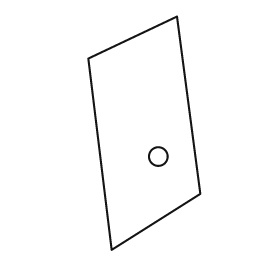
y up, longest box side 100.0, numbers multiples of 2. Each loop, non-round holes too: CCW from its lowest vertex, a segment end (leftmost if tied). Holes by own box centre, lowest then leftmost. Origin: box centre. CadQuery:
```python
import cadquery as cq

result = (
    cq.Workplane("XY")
    .moveTo(-14.0, -50.0)
    .lineTo(24.0, -26.0)
    .lineTo(14.0, 50.0)
    .lineTo(-24.0, 32.0)
    .close()
    .moveTo(6.0, -10.0)
    .circle(4.0)
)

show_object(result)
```